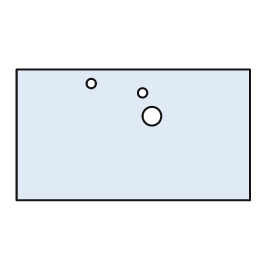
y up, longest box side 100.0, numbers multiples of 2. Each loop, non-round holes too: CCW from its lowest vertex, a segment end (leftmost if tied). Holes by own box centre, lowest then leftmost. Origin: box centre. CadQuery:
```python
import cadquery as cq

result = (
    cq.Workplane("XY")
    .moveTo(-50.0, -28.0)
    .lineTo(50.0, -28.0)
    .lineTo(50.0, 28.0)
    .lineTo(-50.0, 28.0)
    .close()
    .moveTo(8.0, 8.0)
    .circle(4.0)
    .moveTo(4.0, 18.0)
    .circle(2.0)
    .moveTo(-18.0, 22.0)
    .circle(2.0)
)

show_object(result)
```